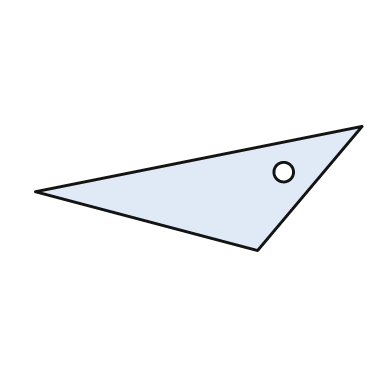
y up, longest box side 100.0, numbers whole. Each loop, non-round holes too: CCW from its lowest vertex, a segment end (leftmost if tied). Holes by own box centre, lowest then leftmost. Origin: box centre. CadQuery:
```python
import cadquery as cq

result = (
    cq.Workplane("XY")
    .moveTo(18.0, -19.0)
    .lineTo(50.0, 19.0)
    .lineTo(-50.0, -1.0)
    .close()
    .moveTo(26.0, 5.0)
    .circle(3.0)
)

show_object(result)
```